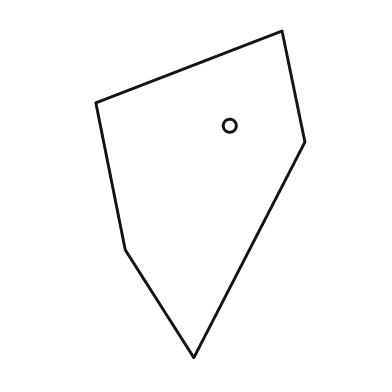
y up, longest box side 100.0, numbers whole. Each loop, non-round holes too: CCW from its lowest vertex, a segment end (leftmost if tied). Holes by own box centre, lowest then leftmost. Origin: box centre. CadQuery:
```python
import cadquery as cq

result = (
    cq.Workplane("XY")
    .moveTo(-2.0, -50.0)
    .lineTo(32.0, 16.0)
    .lineTo(25.0, 50.0)
    .lineTo(-32.0, 28.0)
    .lineTo(-23.0, -17.0)
    .close()
    .moveTo(9.0, 21.0)
    .circle(2.0)
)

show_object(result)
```